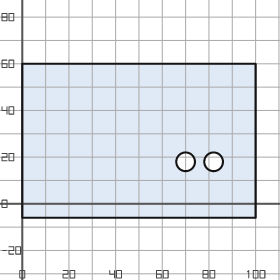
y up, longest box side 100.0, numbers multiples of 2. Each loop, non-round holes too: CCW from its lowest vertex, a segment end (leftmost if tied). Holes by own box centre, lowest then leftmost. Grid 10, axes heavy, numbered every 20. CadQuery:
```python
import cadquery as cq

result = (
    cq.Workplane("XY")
    .moveTo(0.0, -6.0)
    .lineTo(100.0, -6.0)
    .lineTo(100.0, 60.0)
    .lineTo(0.0, 60.0)
    .close()
    .moveTo(70.0, 18.0)
    .circle(4.0)
    .moveTo(82.0, 18.0)
    .circle(4.0)
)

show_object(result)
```